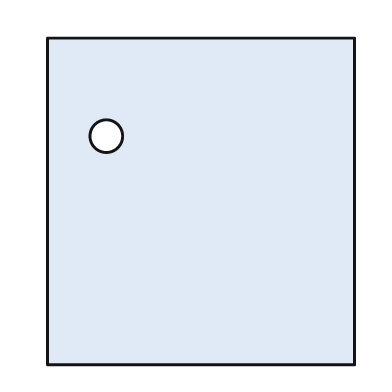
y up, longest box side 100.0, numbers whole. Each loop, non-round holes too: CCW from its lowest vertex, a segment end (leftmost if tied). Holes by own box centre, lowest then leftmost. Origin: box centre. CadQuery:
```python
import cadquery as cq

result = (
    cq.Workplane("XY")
    .moveTo(-47.0, -50.0)
    .lineTo(47.0, -50.0)
    .lineTo(47.0, 50.0)
    .lineTo(-47.0, 50.0)
    .close()
    .moveTo(-29.0, 20.0)
    .circle(5.0)
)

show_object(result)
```